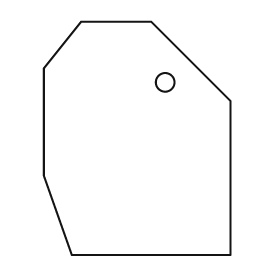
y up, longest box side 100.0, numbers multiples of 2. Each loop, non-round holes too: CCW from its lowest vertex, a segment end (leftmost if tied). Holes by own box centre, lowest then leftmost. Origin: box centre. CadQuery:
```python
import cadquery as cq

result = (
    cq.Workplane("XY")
    .moveTo(-28.0, -50.0)
    .lineTo(40.0, -50.0)
    .lineTo(40.0, 16.0)
    .lineTo(6.0, 50.0)
    .lineTo(-24.0, 50.0)
    .lineTo(-40.0, 30.0)
    .lineTo(-40.0, -16.0)
    .close()
    .moveTo(12.0, 24.0)
    .circle(4.0)
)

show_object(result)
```